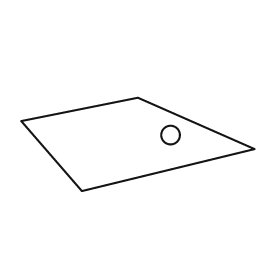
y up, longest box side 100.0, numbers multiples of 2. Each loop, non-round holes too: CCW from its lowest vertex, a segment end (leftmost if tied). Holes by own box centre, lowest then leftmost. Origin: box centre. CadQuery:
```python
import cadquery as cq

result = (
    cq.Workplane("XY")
    .moveTo(-24.0, -20.0)
    .lineTo(50.0, -2.0)
    .lineTo(0.0, 20.0)
    .lineTo(-50.0, 10.0)
    .close()
    .moveTo(14.0, 4.0)
    .circle(4.0)
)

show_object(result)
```